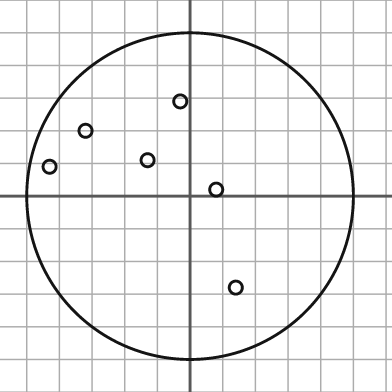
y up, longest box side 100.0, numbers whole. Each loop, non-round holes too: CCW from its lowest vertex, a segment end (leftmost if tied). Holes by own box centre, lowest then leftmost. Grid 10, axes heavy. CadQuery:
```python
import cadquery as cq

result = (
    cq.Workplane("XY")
    .moveTo(0.0, 0.0)
    .circle(50.0)
    .moveTo(14.0, -28.0)
    .circle(2.0)
    .moveTo(8.0, 2.0)
    .circle(2.0)
    .moveTo(-43.0, 9.0)
    .circle(2.0)
    .moveTo(-13.0, 11.0)
    .circle(2.0)
    .moveTo(-32.0, 20.0)
    .circle(2.0)
    .moveTo(-3.0, 29.0)
    .circle(2.0)
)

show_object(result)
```